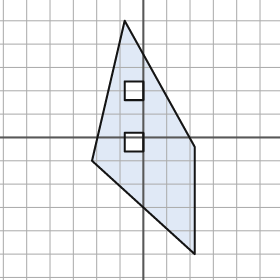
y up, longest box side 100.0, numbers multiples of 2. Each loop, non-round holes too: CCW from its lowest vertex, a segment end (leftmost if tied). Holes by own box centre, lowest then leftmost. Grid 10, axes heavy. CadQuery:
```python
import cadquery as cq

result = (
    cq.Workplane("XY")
    .moveTo(22.0, -50.0)
    .lineTo(22.0, -4.0)
    .lineTo(-8.0, 50.0)
    .lineTo(-22.0, -10.0)
    .close()
    .moveTo(-8.0, -6.0)
    .lineTo(0.0, -6.0)
    .lineTo(0.0, 2.0)
    .lineTo(-8.0, 2.0)
    .close()
    .moveTo(-8.0, 16.0)
    .lineTo(0.0, 16.0)
    .lineTo(0.0, 24.0)
    .lineTo(-8.0, 24.0)
    .close()
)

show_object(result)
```